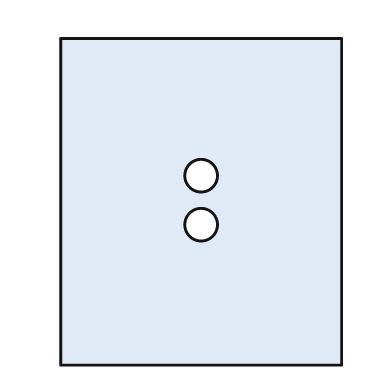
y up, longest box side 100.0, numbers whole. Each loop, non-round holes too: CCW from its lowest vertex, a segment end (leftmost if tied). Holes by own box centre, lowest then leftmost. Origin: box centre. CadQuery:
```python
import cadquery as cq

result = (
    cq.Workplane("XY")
    .moveTo(-43.0, -50.0)
    .lineTo(43.0, -50.0)
    .lineTo(43.0, 50.0)
    .lineTo(-43.0, 50.0)
    .close()
    .moveTo(0.0, -7.0)
    .circle(5.0)
    .moveTo(0.0, 8.0)
    .circle(5.0)
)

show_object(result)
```